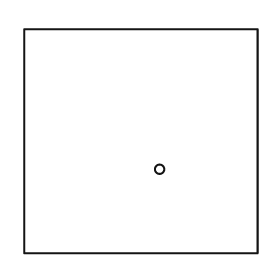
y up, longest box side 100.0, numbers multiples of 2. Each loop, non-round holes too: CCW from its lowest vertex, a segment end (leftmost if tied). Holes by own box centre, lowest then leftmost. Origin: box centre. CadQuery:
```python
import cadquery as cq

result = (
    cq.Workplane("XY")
    .moveTo(-50.0, -48.0)
    .lineTo(50.0, -48.0)
    .lineTo(50.0, 48.0)
    .lineTo(-50.0, 48.0)
    .close()
    .moveTo(8.0, -12.0)
    .circle(2.0)
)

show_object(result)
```